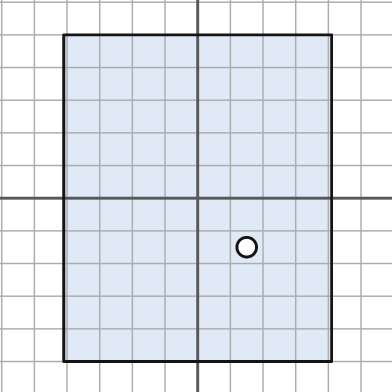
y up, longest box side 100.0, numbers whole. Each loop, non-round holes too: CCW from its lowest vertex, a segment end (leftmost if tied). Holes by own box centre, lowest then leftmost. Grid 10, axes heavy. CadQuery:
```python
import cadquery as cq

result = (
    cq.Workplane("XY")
    .moveTo(-41.0, -50.0)
    .lineTo(41.0, -50.0)
    .lineTo(41.0, 50.0)
    .lineTo(-41.0, 50.0)
    .close()
    .moveTo(15.0, -15.0)
    .circle(3.0)
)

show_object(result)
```